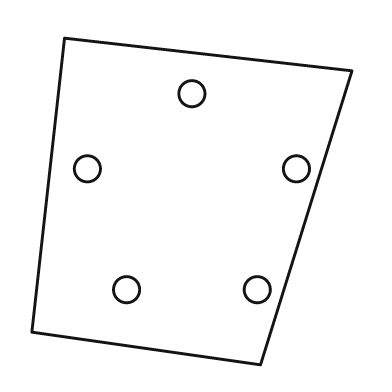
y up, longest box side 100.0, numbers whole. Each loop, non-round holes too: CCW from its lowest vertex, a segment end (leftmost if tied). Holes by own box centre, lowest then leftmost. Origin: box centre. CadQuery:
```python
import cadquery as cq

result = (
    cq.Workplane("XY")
    .moveTo(21.0, -50.0)
    .lineTo(49.0, 40.0)
    .lineTo(-39.0, 50.0)
    .lineTo(-49.0, -40.0)
    .close()
    .moveTo(-20.0, -27.0)
    .circle(4.0)
    .moveTo(20.0, -27.0)
    .circle(4.0)
    .moveTo(-32.0, 10.0)
    .circle(4.0)
    .moveTo(32.0, 10.0)
    .circle(4.0)
    .moveTo(0.0, 33.0)
    .circle(4.0)
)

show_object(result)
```